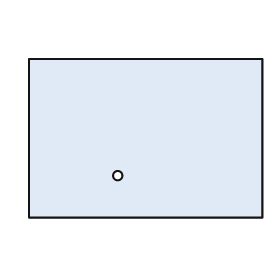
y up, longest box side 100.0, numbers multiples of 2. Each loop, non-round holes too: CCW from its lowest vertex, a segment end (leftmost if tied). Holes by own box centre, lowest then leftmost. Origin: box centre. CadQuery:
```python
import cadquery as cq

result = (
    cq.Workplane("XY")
    .moveTo(-50.0, -34.0)
    .lineTo(50.0, -34.0)
    .lineTo(50.0, 34.0)
    .lineTo(-50.0, 34.0)
    .close()
    .moveTo(-12.0, -16.0)
    .circle(2.0)
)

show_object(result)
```